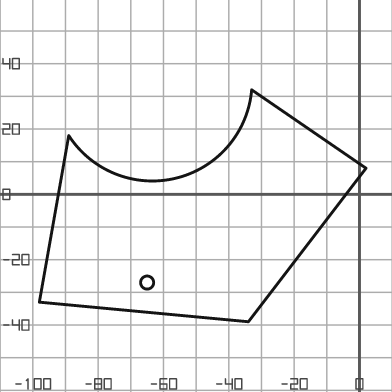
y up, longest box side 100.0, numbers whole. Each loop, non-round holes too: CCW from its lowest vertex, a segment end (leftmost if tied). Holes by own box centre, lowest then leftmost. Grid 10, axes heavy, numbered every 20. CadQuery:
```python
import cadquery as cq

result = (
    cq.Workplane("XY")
    .moveTo(-34.0, -39.0)
    .lineTo(2.0, 8.0)
    .lineTo(-33.0, 32.0)
    .threePointArc((-56.0, 5.0), (-89.0, 18.0))
    .lineTo(-98.0, -33.0)
    .close()
    .moveTo(-65.0, -27.0)
    .circle(2.0)
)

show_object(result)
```